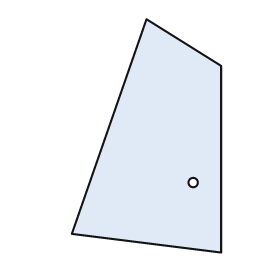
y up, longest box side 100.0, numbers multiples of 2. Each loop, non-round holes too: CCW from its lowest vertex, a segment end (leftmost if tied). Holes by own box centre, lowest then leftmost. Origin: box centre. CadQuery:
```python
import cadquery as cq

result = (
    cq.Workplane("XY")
    .moveTo(32.0, -50.0)
    .lineTo(32.0, 30.0)
    .lineTo(0.0, 50.0)
    .lineTo(-32.0, -42.0)
    .close()
    .moveTo(20.0, -20.0)
    .circle(2.0)
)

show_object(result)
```